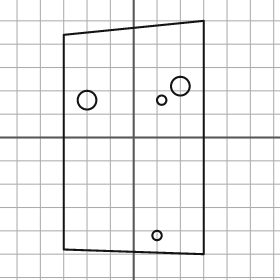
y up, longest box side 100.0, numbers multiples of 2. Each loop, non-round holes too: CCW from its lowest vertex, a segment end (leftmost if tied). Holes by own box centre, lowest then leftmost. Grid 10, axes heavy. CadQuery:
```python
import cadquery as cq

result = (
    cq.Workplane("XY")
    .moveTo(30.0, -50.0)
    .lineTo(30.0, 50.0)
    .lineTo(-30.0, 44.0)
    .lineTo(-30.0, -48.0)
    .close()
    .moveTo(10.0, -42.0)
    .circle(2.0)
    .moveTo(-20.0, 16.0)
    .circle(4.0)
    .moveTo(12.0, 16.0)
    .circle(2.0)
    .moveTo(20.0, 22.0)
    .circle(4.0)
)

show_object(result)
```